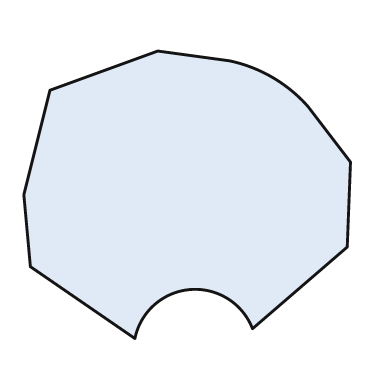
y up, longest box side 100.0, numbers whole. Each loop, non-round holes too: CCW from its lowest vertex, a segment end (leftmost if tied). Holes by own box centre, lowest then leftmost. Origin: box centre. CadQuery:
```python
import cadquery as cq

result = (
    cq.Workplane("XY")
    .moveTo(-16.0, -44.0)
    .threePointArc((1.0, -29.0), (20.0, -41.0))
    .lineTo(49.0, -16.0)
    .lineTo(50.0, 10.0)
    .lineTo(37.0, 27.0)
    .threePointArc((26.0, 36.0), (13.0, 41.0))
    .lineTo(-9.0, 44.0)
    .lineTo(-42.0, 32.0)
    .lineTo(-50.0, 0.0)
    .lineTo(-48.0, -22.0)
    .close()
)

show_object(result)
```